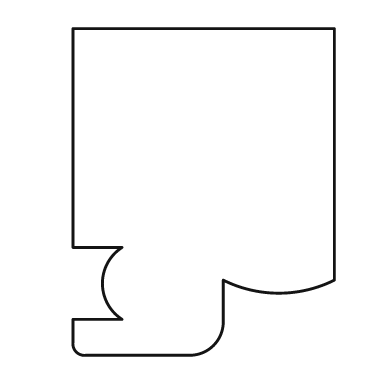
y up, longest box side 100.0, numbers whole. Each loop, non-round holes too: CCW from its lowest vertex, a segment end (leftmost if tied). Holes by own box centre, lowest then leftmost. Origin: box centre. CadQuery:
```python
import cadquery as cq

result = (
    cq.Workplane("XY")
    .moveTo(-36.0, -50.0)
    .lineTo(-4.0, -50.0)
    .threePointArc((3.0, -47.0), (6.0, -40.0))
    .lineTo(6.0, -27.0)
    .threePointArc((23.0, -31.0), (40.0, -27.0))
    .lineTo(40.0, 50.0)
    .lineTo(-40.0, 50.0)
    .lineTo(-40.0, -17.0)
    .lineTo(-25.0, -17.0)
    .threePointArc((-31.0, -28.0), (-25.0, -39.0))
    .lineTo(-40.0, -39.0)
    .lineTo(-40.0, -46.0)
    .threePointArc((-39.0, -49.0), (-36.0, -50.0))
    .close()
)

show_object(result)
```